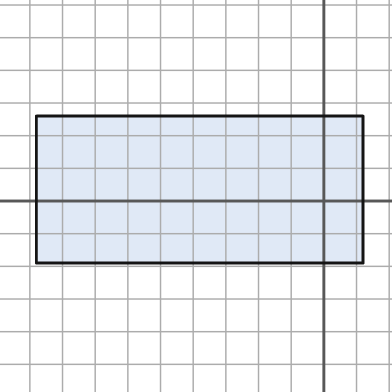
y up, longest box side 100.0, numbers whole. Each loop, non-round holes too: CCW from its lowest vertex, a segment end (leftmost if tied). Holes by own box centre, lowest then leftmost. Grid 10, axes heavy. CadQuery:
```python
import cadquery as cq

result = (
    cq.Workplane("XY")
    .moveTo(-88.0, -19.0)
    .lineTo(12.0, -19.0)
    .lineTo(12.0, 26.0)
    .lineTo(-88.0, 26.0)
    .close()
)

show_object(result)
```